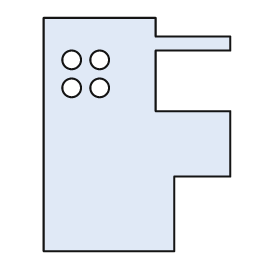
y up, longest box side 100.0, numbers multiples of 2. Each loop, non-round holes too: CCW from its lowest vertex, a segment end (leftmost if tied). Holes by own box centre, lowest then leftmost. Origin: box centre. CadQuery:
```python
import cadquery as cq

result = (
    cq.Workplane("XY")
    .moveTo(-40.0, -50.0)
    .lineTo(16.0, -50.0)
    .lineTo(16.0, -18.0)
    .lineTo(40.0, -18.0)
    .lineTo(40.0, 10.0)
    .lineTo(8.0, 10.0)
    .lineTo(8.0, 36.0)
    .lineTo(40.0, 36.0)
    .lineTo(40.0, 42.0)
    .lineTo(8.0, 42.0)
    .lineTo(8.0, 50.0)
    .lineTo(-40.0, 50.0)
    .close()
    .moveTo(-28.0, 20.0)
    .circle(4.0)
    .moveTo(-16.0, 20.0)
    .circle(4.0)
    .moveTo(-28.0, 32.0)
    .circle(4.0)
    .moveTo(-16.0, 32.0)
    .circle(4.0)
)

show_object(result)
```